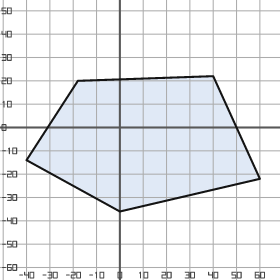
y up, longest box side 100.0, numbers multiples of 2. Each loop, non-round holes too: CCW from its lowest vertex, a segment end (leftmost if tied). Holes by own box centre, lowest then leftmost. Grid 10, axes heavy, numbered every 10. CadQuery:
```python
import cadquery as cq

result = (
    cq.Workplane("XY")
    .moveTo(0.0, -36.0)
    .lineTo(60.0, -22.0)
    .lineTo(40.0, 22.0)
    .lineTo(-18.0, 20.0)
    .lineTo(-40.0, -14.0)
    .close()
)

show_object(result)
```